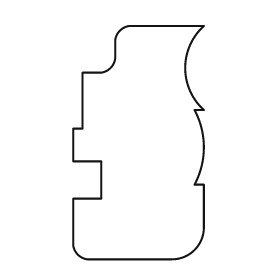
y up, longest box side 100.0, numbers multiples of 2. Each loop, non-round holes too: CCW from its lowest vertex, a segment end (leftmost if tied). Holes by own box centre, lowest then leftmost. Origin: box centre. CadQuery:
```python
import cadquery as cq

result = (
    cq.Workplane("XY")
    .moveTo(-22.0, -50.0)
    .lineTo(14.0, -50.0)
    .threePointArc((24.0, -46.0), (28.0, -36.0))
    .lineTo(28.0, -18.0)
    .lineTo(24.0, -18.0)
    .threePointArc((28.0, -2.0), (24.0, 14.0))
    .lineTo(28.0, 14.0)
    .threePointArc((20.0, 32.0), (28.0, 50.0))
    .lineTo(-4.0, 50.0)
    .threePointArc((-8.0, 48.0), (-10.0, 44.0))
    .lineTo(-10.0, 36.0)
    .threePointArc((-12.0, 32.0), (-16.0, 30.0))
    .lineTo(-24.0, 30.0)
    .lineTo(-24.0, 6.0)
    .lineTo(-28.0, 6.0)
    .lineTo(-28.0, -8.0)
    .lineTo(-16.0, -8.0)
    .lineTo(-16.0, -24.0)
    .lineTo(-28.0, -24.0)
    .lineTo(-28.0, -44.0)
    .threePointArc((-26.0, -48.0), (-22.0, -50.0))
    .close()
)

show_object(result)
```